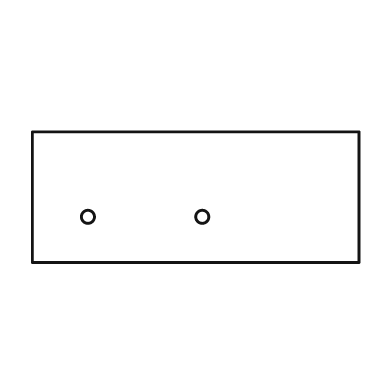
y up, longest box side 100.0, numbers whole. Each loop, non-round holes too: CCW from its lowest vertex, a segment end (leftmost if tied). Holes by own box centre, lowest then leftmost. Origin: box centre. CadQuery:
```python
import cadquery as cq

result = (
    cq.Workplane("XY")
    .moveTo(-50.0, -20.0)
    .lineTo(50.0, -20.0)
    .lineTo(50.0, 20.0)
    .lineTo(-50.0, 20.0)
    .close()
    .moveTo(-33.0, -6.0)
    .circle(2.0)
    .moveTo(2.0, -6.0)
    .circle(2.0)
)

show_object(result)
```